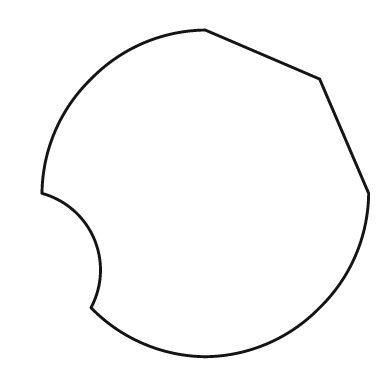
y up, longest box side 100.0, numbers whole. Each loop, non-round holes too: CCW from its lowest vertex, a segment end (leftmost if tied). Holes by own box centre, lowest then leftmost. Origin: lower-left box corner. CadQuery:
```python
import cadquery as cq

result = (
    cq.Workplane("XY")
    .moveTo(50.0, 0.0)
    .threePointArc((69.0, 4.0), (85.0, 15.0))
    .threePointArc((96.0, 31.0), (100.0, 50.0))
    .lineTo(85.0, 85.0)
    .lineTo(50.0, 100.0)
    .threePointArc((31.0, 96.0), (15.0, 85.0))
    .threePointArc((4.0, 69.0), (0.0, 50.0))
    .threePointArc((16.0, 36.0), (15.0, 15.0))
    .threePointArc((31.0, 4.0), (50.0, 0.0))
    .close()
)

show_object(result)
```